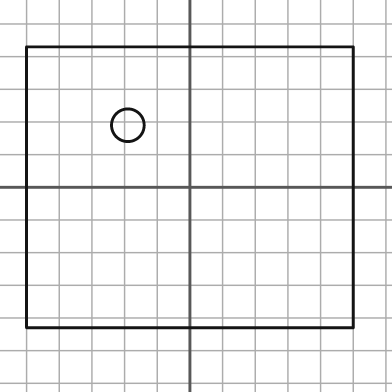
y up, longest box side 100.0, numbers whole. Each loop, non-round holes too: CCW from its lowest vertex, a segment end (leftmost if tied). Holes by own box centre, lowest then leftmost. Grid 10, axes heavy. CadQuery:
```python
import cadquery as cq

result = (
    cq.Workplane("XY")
    .moveTo(-50.0, -43.0)
    .lineTo(50.0, -43.0)
    .lineTo(50.0, 43.0)
    .lineTo(-50.0, 43.0)
    .close()
    .moveTo(-19.0, 19.0)
    .circle(5.0)
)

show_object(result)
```